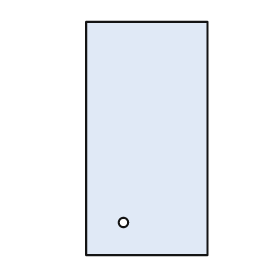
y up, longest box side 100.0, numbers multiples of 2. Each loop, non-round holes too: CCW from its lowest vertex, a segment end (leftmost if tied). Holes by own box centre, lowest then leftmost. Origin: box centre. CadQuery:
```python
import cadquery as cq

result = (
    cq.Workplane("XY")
    .moveTo(-26.0, -50.0)
    .lineTo(26.0, -50.0)
    .lineTo(26.0, 50.0)
    .lineTo(-26.0, 50.0)
    .close()
    .moveTo(-10.0, -36.0)
    .circle(2.0)
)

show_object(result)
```